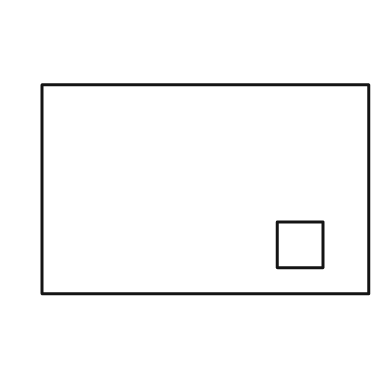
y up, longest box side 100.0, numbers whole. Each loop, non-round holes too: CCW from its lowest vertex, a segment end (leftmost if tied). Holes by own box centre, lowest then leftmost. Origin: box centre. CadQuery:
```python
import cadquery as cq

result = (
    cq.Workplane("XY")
    .moveTo(-50.0, -32.0)
    .lineTo(50.0, -32.0)
    .lineTo(50.0, 32.0)
    .lineTo(-50.0, 32.0)
    .close()
    .moveTo(22.0, -24.0)
    .lineTo(36.0, -24.0)
    .lineTo(36.0, -10.0)
    .lineTo(22.0, -10.0)
    .close()
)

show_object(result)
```